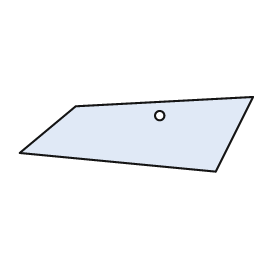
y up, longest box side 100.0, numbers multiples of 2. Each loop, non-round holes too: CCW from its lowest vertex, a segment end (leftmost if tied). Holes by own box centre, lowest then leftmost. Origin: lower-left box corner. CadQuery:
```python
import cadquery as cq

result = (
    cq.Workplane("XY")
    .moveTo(84.0, 0.0)
    .lineTo(100.0, 32.0)
    .lineTo(24.0, 28.0)
    .lineTo(0.0, 8.0)
    .close()
    .moveTo(60.0, 24.0)
    .circle(2.0)
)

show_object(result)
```